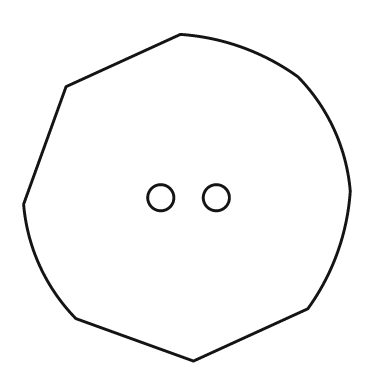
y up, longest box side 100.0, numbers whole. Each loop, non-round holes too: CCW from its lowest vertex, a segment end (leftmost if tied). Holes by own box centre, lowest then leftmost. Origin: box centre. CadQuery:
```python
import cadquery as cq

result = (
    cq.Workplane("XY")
    .moveTo(2.0, -50.0)
    .lineTo(37.0, -34.0)
    .threePointArc((46.0, -17.0), (50.0, 2.0))
    .threePointArc((45.0, 21.0), (34.0, 37.0))
    .threePointArc((17.0, 46.0), (-2.0, 50.0))
    .lineTo(-37.0, 34.0)
    .lineTo(-50.0, -2.0)
    .threePointArc((-45.0, -21.0), (-34.0, -37.0))
    .close()
    .moveTo(-8.0, 0.0)
    .circle(4.0)
    .moveTo(9.0, 0.0)
    .circle(4.0)
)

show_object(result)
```